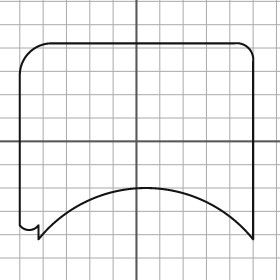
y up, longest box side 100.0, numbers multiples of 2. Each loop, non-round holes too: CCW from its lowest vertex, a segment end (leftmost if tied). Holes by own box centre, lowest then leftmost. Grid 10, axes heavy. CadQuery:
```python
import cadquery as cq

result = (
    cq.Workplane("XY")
    .moveTo(-42.0, -42.0)
    .threePointArc((4.0, -20.0), (50.0, -42.0))
    .lineTo(50.0, 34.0)
    .threePointArc((48.0, 40.0), (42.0, 42.0))
    .lineTo(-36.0, 42.0)
    .threePointArc((-46.0, 38.0), (-50.0, 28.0))
    .lineTo(-50.0, -36.0)
    .threePointArc((-46.0, -38.0), (-42.0, -36.0))
    .close()
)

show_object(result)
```